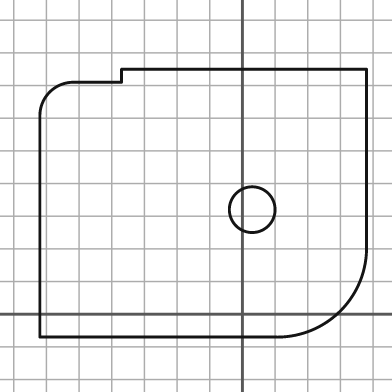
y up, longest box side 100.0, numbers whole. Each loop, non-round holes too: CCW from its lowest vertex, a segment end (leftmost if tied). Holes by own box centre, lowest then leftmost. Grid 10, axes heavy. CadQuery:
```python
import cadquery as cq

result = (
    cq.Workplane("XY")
    .moveTo(-62.0, -7.0)
    .lineTo(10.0, -7.0)
    .threePointArc((30.0, 1.0), (38.0, 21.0))
    .lineTo(38.0, 75.0)
    .lineTo(-37.0, 75.0)
    .lineTo(-37.0, 71.0)
    .lineTo(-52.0, 71.0)
    .threePointArc((-59.0, 68.0), (-62.0, 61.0))
    .close()
    .moveTo(3.0, 32.0)
    .circle(7.0)
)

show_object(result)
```